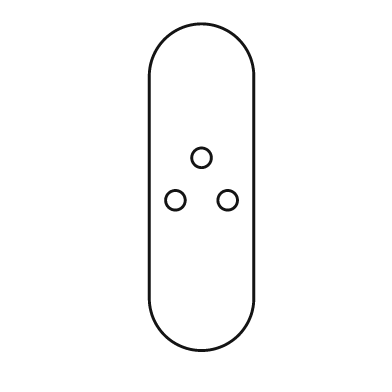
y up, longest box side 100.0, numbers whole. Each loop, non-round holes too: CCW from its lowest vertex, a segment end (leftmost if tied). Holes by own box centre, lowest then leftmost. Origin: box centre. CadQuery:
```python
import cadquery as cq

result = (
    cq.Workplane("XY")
    .moveTo(-16.0, -34.0)
    .threePointArc((0.0, -50.0), (16.0, -34.0))
    .lineTo(16.0, 34.0)
    .threePointArc((0.0, 50.0), (-16.0, 34.0))
    .close()
    .moveTo(-8.0, -4.0)
    .circle(3.0)
    .moveTo(8.0, -4.0)
    .circle(3.0)
    .moveTo(0.0, 9.0)
    .circle(3.0)
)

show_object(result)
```